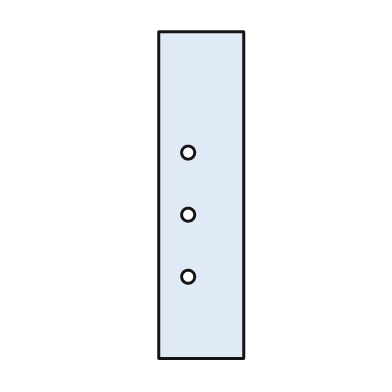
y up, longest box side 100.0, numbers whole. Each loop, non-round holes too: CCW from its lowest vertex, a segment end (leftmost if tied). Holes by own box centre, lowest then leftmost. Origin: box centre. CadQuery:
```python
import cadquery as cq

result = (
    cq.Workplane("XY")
    .moveTo(-13.0, -50.0)
    .lineTo(13.0, -50.0)
    .lineTo(13.0, 50.0)
    .lineTo(-13.0, 50.0)
    .close()
    .moveTo(-4.0, -25.0)
    .circle(2.0)
    .moveTo(-4.0, -6.0)
    .circle(2.0)
    .moveTo(-4.0, 13.0)
    .circle(2.0)
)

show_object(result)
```